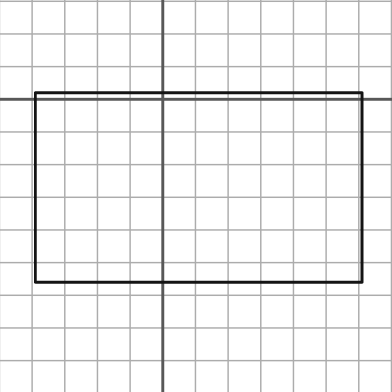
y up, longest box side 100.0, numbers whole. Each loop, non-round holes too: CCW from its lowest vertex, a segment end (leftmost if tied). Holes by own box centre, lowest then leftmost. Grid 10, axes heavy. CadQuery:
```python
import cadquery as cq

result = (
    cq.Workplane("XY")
    .moveTo(-39.0, -56.0)
    .lineTo(61.0, -56.0)
    .lineTo(61.0, 2.0)
    .lineTo(-39.0, 2.0)
    .close()
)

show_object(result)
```